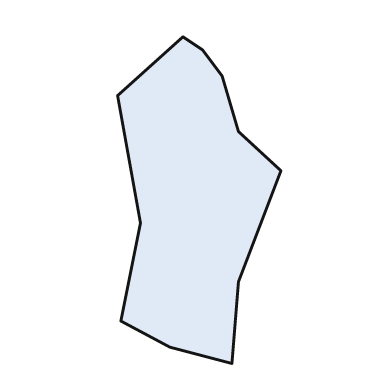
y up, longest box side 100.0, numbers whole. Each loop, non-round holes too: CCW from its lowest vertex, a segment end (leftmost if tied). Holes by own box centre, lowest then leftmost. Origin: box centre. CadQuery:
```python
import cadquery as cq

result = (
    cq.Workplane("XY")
    .moveTo(10.0, -50.0)
    .lineTo(12.0, -25.0)
    .lineTo(25.0, 9.0)
    .lineTo(12.0, 21.0)
    .lineTo(7.0, 38.0)
    .lineTo(1.0, 46.0)
    .lineTo(-5.0, 50.0)
    .lineTo(-25.0, 32.0)
    .lineTo(-18.0, -7.0)
    .lineTo(-24.0, -37.0)
    .lineTo(-9.0, -45.0)
    .close()
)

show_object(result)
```